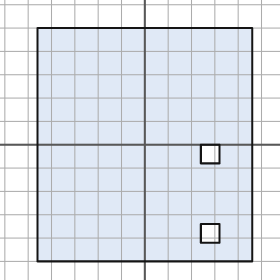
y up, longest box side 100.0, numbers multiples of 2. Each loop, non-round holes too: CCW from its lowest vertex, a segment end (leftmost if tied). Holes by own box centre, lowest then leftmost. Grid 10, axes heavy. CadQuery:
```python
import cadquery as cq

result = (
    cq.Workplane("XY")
    .moveTo(-46.0, -50.0)
    .lineTo(46.0, -50.0)
    .lineTo(46.0, 50.0)
    .lineTo(-46.0, 50.0)
    .close()
    .moveTo(24.0, -42.0)
    .lineTo(32.0, -42.0)
    .lineTo(32.0, -34.0)
    .lineTo(24.0, -34.0)
    .close()
    .moveTo(24.0, -8.0)
    .lineTo(32.0, -8.0)
    .lineTo(32.0, 0.0)
    .lineTo(24.0, 0.0)
    .close()
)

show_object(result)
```